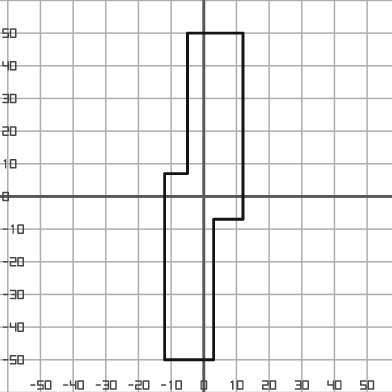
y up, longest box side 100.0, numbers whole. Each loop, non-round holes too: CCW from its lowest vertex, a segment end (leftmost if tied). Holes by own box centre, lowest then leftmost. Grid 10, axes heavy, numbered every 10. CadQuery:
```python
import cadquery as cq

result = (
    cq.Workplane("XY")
    .moveTo(-12.0, -50.0)
    .lineTo(3.0, -50.0)
    .lineTo(3.0, -7.0)
    .lineTo(12.0, -7.0)
    .lineTo(12.0, 50.0)
    .lineTo(-5.0, 50.0)
    .lineTo(-5.0, 7.0)
    .lineTo(-12.0, 7.0)
    .close()
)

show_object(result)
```